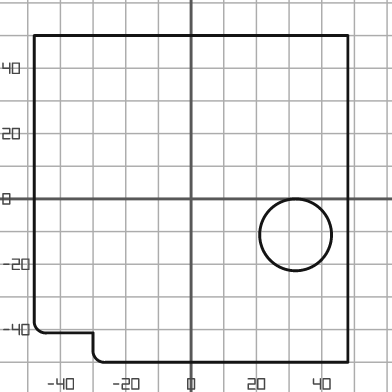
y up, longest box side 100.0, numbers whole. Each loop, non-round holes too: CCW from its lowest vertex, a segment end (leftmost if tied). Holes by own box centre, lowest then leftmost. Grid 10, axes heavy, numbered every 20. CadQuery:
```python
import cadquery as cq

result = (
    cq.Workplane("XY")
    .moveTo(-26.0, -50.0)
    .lineTo(48.0, -50.0)
    .lineTo(48.0, 50.0)
    .lineTo(-48.0, 50.0)
    .lineTo(-48.0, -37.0)
    .threePointArc((-47.0, -40.0), (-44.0, -41.0))
    .lineTo(-30.0, -41.0)
    .lineTo(-30.0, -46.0)
    .threePointArc((-29.0, -49.0), (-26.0, -50.0))
    .close()
    .moveTo(32.0, -11.0)
    .circle(11.0)
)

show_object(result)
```